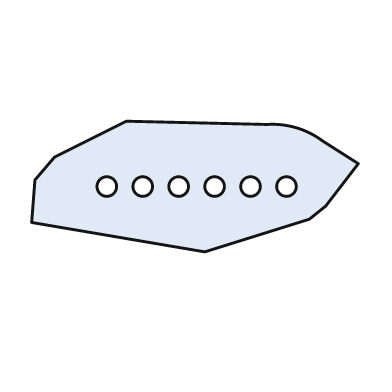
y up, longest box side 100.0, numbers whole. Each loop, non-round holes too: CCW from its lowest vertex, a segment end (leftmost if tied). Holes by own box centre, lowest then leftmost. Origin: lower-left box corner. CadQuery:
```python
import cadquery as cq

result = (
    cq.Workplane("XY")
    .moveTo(53.0, 0.0)
    .lineTo(85.0, 10.0)
    .lineTo(90.0, 14.0)
    .lineTo(100.0, 27.0)
    .lineTo(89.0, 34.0)
    .threePointArc((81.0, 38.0), (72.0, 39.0))
    .lineTo(29.0, 40.0)
    .lineTo(7.0, 29.0)
    .lineTo(1.0, 22.0)
    .lineTo(0.0, 9.0)
    .close()
    .moveTo(23.0, 20.0)
    .circle(3.0)
    .moveTo(34.0, 20.0)
    .circle(3.0)
    .moveTo(45.0, 20.0)
    .circle(3.0)
    .moveTo(56.0, 20.0)
    .circle(3.0)
    .moveTo(67.0, 20.0)
    .circle(3.0)
    .moveTo(78.0, 20.0)
    .circle(3.0)
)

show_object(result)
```